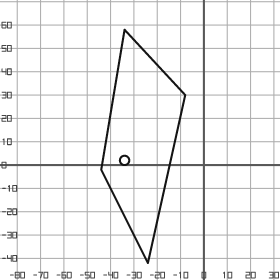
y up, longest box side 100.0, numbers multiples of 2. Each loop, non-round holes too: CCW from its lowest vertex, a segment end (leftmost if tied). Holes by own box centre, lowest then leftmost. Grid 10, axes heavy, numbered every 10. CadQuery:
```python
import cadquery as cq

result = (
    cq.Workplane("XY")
    .moveTo(-24.0, -42.0)
    .lineTo(-8.0, 30.0)
    .lineTo(-34.0, 58.0)
    .lineTo(-44.0, -2.0)
    .close()
    .moveTo(-34.0, 2.0)
    .circle(2.0)
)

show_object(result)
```